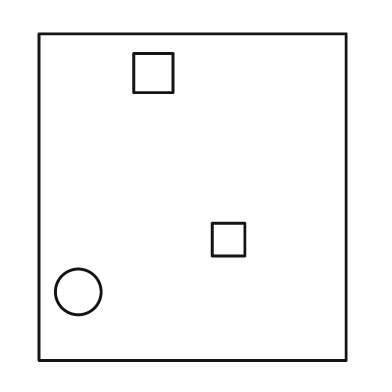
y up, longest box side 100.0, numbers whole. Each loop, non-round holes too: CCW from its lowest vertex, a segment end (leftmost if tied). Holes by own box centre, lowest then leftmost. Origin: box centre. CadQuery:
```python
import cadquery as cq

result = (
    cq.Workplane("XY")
    .moveTo(-47.0, -50.0)
    .lineTo(47.0, -50.0)
    .lineTo(47.0, 50.0)
    .lineTo(-47.0, 50.0)
    .close()
    .moveTo(-35.0, -29.0)
    .circle(7.0)
    .moveTo(6.0, -18.0)
    .lineTo(16.0, -18.0)
    .lineTo(16.0, -8.0)
    .lineTo(6.0, -8.0)
    .close()
    .moveTo(-18.0, 32.0)
    .lineTo(-6.0, 32.0)
    .lineTo(-6.0, 44.0)
    .lineTo(-18.0, 44.0)
    .close()
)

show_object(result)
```